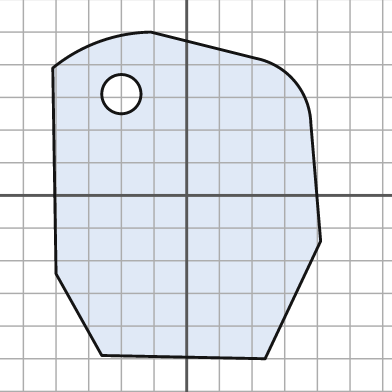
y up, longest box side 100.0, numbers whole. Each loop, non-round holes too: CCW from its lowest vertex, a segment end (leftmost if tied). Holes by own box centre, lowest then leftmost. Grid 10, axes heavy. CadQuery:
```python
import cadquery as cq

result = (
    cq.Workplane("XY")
    .moveTo(24.0, -50.0)
    .lineTo(41.0, -14.0)
    .lineTo(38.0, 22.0)
    .threePointArc((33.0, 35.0), (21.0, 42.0))
    .lineTo(-11.0, 50.0)
    .threePointArc((-27.0, 47.0), (-41.0, 39.0))
    .lineTo(-40.0, -24.0)
    .lineTo(-26.0, -49.0)
    .close()
    .moveTo(-20.0, 31.0)
    .circle(6.0)
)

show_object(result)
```